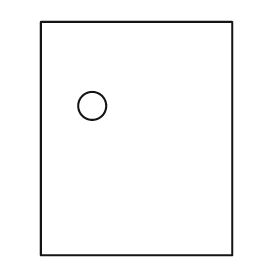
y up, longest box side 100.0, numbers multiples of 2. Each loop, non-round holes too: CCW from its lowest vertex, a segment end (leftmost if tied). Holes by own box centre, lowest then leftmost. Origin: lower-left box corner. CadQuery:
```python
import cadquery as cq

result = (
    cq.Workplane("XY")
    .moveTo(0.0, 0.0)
    .lineTo(82.0, 0.0)
    .lineTo(82.0, 100.0)
    .lineTo(0.0, 100.0)
    .close()
    .moveTo(22.0, 64.0)
    .circle(6.0)
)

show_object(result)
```